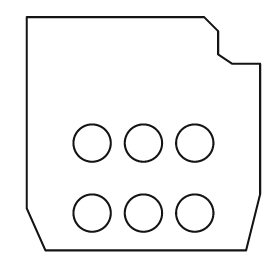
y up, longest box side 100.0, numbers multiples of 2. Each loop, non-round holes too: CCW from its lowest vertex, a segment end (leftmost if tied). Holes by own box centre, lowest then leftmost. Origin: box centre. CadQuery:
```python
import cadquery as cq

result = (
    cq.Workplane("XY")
    .moveTo(-42.0, -50.0)
    .lineTo(44.0, -50.0)
    .lineTo(50.0, -26.0)
    .lineTo(50.0, 30.0)
    .lineTo(38.0, 30.0)
    .lineTo(32.0, 34.0)
    .lineTo(32.0, 44.0)
    .lineTo(26.0, 50.0)
    .lineTo(-50.0, 50.0)
    .lineTo(-50.0, -32.0)
    .close()
    .moveTo(-22.0, -34.0)
    .circle(8.0)
    .moveTo(0.0, -34.0)
    .circle(8.0)
    .moveTo(22.0, -34.0)
    .circle(8.0)
    .moveTo(-22.0, -4.0)
    .circle(8.0)
    .moveTo(0.0, -4.0)
    .circle(8.0)
    .moveTo(22.0, -4.0)
    .circle(8.0)
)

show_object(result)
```